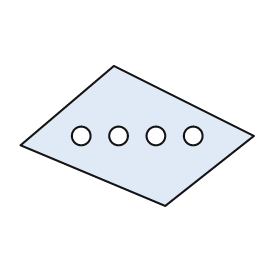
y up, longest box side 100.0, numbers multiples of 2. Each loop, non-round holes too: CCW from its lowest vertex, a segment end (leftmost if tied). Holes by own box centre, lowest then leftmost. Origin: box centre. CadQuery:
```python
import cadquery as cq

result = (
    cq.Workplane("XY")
    .moveTo(12.0, -30.0)
    .lineTo(50.0, 0.0)
    .lineTo(-10.0, 30.0)
    .lineTo(-50.0, -4.0)
    .close()
    .moveTo(-24.0, 0.0)
    .circle(4.0)
    .moveTo(-8.0, 0.0)
    .circle(4.0)
    .moveTo(8.0, 0.0)
    .circle(4.0)
    .moveTo(24.0, 0.0)
    .circle(4.0)
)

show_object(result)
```